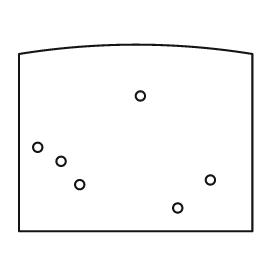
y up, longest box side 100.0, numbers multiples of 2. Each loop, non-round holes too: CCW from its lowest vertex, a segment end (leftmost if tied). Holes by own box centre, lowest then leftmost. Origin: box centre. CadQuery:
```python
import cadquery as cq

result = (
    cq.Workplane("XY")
    .moveTo(-50.0, -40.0)
    .lineTo(50.0, -40.0)
    .lineTo(50.0, 36.0)
    .threePointArc((0.0, 40.0), (-50.0, 36.0))
    .close()
    .moveTo(18.0, -30.0)
    .circle(2.0)
    .moveTo(-24.0, -20.0)
    .circle(2.0)
    .moveTo(32.0, -18.0)
    .circle(2.0)
    .moveTo(-32.0, -10.0)
    .circle(2.0)
    .moveTo(-42.0, -4.0)
    .circle(2.0)
    .moveTo(2.0, 18.0)
    .circle(2.0)
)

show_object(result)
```